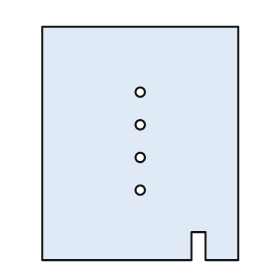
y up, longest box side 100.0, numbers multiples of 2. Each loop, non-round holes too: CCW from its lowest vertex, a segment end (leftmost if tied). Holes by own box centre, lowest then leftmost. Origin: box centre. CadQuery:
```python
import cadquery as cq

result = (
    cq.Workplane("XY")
    .moveTo(-42.0, -50.0)
    .lineTo(22.0, -50.0)
    .lineTo(22.0, -38.0)
    .lineTo(28.0, -38.0)
    .lineTo(28.0, -50.0)
    .lineTo(42.0, -50.0)
    .lineTo(42.0, 50.0)
    .lineTo(-42.0, 50.0)
    .close()
    .moveTo(0.0, -20.0)
    .circle(2.0)
    .moveTo(0.0, -6.0)
    .circle(2.0)
    .moveTo(0.0, 8.0)
    .circle(2.0)
    .moveTo(0.0, 22.0)
    .circle(2.0)
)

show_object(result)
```